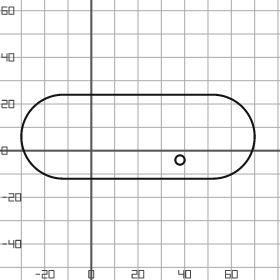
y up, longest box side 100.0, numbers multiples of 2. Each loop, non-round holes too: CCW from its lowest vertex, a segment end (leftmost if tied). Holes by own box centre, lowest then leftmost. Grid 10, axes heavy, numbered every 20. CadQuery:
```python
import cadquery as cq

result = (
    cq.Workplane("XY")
    .moveTo(-12.0, -12.0)
    .lineTo(52.0, -12.0)
    .threePointArc((70.0, 6.0), (52.0, 24.0))
    .lineTo(-12.0, 24.0)
    .threePointArc((-30.0, 6.0), (-12.0, -12.0))
    .close()
    .moveTo(38.0, -4.0)
    .circle(2.0)
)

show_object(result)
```